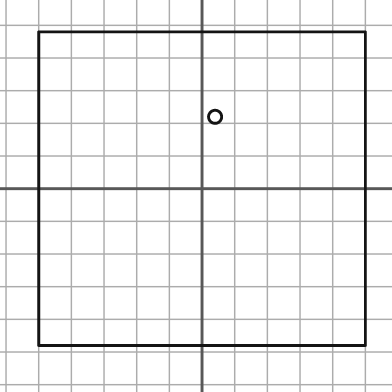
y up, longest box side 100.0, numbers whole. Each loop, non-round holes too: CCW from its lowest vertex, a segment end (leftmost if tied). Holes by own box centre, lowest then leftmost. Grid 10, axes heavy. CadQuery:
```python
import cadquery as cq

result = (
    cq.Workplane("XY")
    .moveTo(-50.0, -48.0)
    .lineTo(50.0, -48.0)
    .lineTo(50.0, 48.0)
    .lineTo(-50.0, 48.0)
    .close()
    .moveTo(4.0, 22.0)
    .circle(2.0)
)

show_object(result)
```